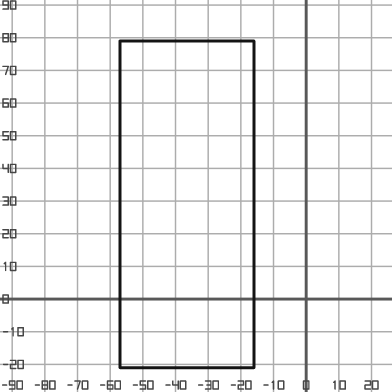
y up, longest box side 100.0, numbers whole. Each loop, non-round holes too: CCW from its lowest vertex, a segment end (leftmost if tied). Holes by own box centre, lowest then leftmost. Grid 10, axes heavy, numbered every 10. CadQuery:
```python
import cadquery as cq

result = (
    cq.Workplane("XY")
    .moveTo(-57.0, -21.0)
    .lineTo(-16.0, -21.0)
    .lineTo(-16.0, 79.0)
    .lineTo(-57.0, 79.0)
    .close()
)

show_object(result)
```